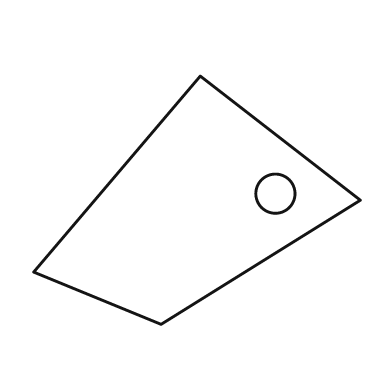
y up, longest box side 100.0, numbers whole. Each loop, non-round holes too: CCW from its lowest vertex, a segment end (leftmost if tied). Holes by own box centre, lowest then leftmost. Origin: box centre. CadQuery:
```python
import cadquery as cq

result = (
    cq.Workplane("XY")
    .moveTo(-11.0, -38.0)
    .lineTo(50.0, 0.0)
    .lineTo(1.0, 38.0)
    .lineTo(-50.0, -22.0)
    .close()
    .moveTo(24.0, 2.0)
    .circle(6.0)
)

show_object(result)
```